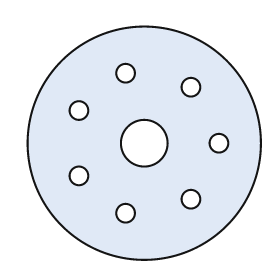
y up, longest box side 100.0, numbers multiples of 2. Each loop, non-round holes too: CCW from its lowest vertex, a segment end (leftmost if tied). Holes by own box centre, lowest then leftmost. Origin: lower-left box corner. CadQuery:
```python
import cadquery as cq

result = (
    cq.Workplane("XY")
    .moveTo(50.0, 50.0)
    .circle(50.0)
    .moveTo(42.0, 20.0)
    .circle(4.0)
    .moveTo(70.0, 26.0)
    .circle(4.0)
    .moveTo(22.0, 36.0)
    .circle(4.0)
    .moveTo(50.0, 50.0)
    .circle(10.0)
    .moveTo(82.0, 50.0)
    .circle(4.0)
    .moveTo(22.0, 64.0)
    .circle(4.0)
    .moveTo(70.0, 74.0)
    .circle(4.0)
    .moveTo(42.0, 80.0)
    .circle(4.0)
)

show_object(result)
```